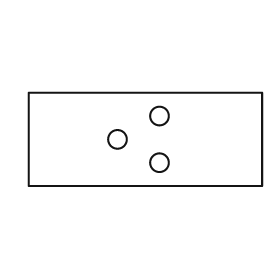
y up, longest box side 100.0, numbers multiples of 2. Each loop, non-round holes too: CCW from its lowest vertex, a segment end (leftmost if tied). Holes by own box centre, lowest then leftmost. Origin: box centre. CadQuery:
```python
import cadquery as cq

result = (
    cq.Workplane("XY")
    .moveTo(-50.0, -20.0)
    .lineTo(50.0, -20.0)
    .lineTo(50.0, 20.0)
    .lineTo(-50.0, 20.0)
    .close()
    .moveTo(6.0, -10.0)
    .circle(4.0)
    .moveTo(-12.0, 0.0)
    .circle(4.0)
    .moveTo(6.0, 10.0)
    .circle(4.0)
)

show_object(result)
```